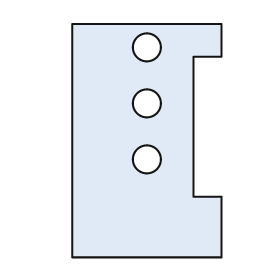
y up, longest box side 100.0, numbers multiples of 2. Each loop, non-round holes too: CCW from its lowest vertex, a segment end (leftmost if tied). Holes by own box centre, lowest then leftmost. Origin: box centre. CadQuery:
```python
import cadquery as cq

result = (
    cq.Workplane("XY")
    .moveTo(-32.0, -50.0)
    .lineTo(32.0, -50.0)
    .lineTo(32.0, -24.0)
    .lineTo(20.0, -24.0)
    .lineTo(20.0, 36.0)
    .lineTo(32.0, 36.0)
    .lineTo(32.0, 50.0)
    .lineTo(-32.0, 50.0)
    .close()
    .moveTo(0.0, -8.0)
    .circle(6.0)
    .moveTo(0.0, 16.0)
    .circle(6.0)
    .moveTo(0.0, 40.0)
    .circle(6.0)
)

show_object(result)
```